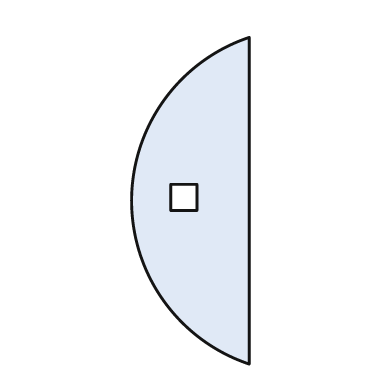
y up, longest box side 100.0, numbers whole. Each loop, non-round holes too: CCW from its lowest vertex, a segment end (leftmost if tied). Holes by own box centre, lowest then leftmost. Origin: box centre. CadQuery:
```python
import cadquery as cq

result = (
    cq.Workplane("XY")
    .moveTo(18.0, -50.0)
    .lineTo(18.0, 50.0)
    .threePointArc((-18.0, 0.0), (18.0, -50.0))
    .close()
    .moveTo(-6.0, -3.0)
    .lineTo(2.0, -3.0)
    .lineTo(2.0, 5.0)
    .lineTo(-6.0, 5.0)
    .close()
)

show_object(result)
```